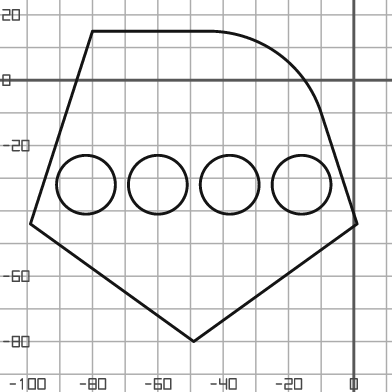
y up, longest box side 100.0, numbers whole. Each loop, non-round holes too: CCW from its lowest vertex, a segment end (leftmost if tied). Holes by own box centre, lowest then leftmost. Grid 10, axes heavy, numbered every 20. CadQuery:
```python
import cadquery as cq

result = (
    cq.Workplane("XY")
    .moveTo(-49.0, -80.0)
    .lineTo(1.0, -44.0)
    .lineTo(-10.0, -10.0)
    .threePointArc((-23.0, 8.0), (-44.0, 15.0))
    .lineTo(-80.0, 15.0)
    .lineTo(-99.0, -44.0)
    .close()
    .moveTo(-82.0, -32.0)
    .circle(9.0)
    .moveTo(-60.0, -32.0)
    .circle(9.0)
    .moveTo(-38.0, -32.0)
    .circle(9.0)
    .moveTo(-16.0, -32.0)
    .circle(9.0)
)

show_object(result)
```